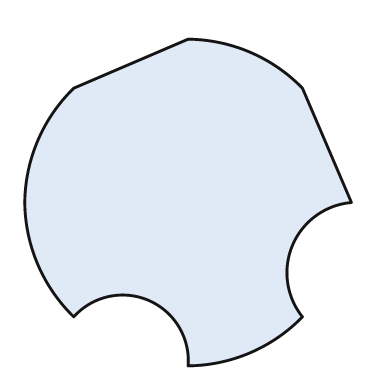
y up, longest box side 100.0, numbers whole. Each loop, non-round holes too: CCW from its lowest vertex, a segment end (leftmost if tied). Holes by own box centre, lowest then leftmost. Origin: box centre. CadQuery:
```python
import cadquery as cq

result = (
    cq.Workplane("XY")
    .moveTo(0.0, -50.0)
    .threePointArc((19.0, -46.0), (35.0, -35.0))
    .threePointArc((32.0, -13.0), (50.0, 0.0))
    .lineTo(35.0, 35.0)
    .threePointArc((19.0, 46.0), (0.0, 50.0))
    .lineTo(-35.0, 35.0)
    .threePointArc((-46.0, 19.0), (-50.0, 0.0))
    .threePointArc((-46.0, -19.0), (-35.0, -35.0))
    .threePointArc((-12.0, -30.0), (0.0, -50.0))
    .close()
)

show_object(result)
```